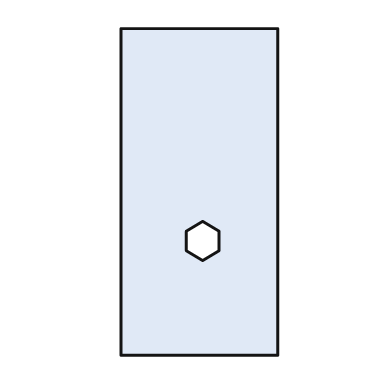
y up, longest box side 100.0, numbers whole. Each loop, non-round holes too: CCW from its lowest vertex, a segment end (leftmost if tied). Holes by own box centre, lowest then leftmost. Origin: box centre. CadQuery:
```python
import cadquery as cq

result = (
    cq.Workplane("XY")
    .moveTo(-24.0, -50.0)
    .lineTo(24.0, -50.0)
    .lineTo(24.0, 50.0)
    .lineTo(-24.0, 50.0)
    .close()
    .moveTo(1.0, -21.0)
    .lineTo(6.0, -18.0)
    .lineTo(6.0, -12.0)
    .lineTo(1.0, -9.0)
    .lineTo(-4.0, -12.0)
    .lineTo(-4.0, -18.0)
    .close()
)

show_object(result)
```